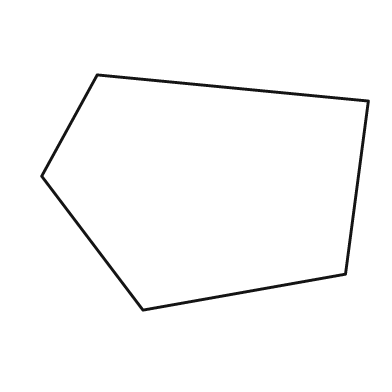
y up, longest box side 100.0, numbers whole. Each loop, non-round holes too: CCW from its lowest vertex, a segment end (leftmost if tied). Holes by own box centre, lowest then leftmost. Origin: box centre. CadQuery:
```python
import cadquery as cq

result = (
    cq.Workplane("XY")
    .moveTo(-19.0, -36.0)
    .lineTo(43.0, -25.0)
    .lineTo(50.0, 28.0)
    .lineTo(-33.0, 36.0)
    .lineTo(-50.0, 5.0)
    .close()
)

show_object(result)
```